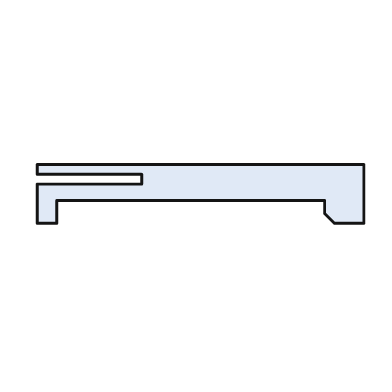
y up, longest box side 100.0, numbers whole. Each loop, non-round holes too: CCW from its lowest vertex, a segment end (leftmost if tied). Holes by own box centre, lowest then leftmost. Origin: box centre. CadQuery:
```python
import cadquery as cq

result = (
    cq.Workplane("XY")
    .moveTo(-50.0, -9.0)
    .lineTo(-44.0, -9.0)
    .lineTo(-44.0, -2.0)
    .lineTo(38.0, -2.0)
    .lineTo(38.0, -6.0)
    .lineTo(41.0, -9.0)
    .lineTo(50.0, -9.0)
    .lineTo(50.0, 9.0)
    .lineTo(-50.0, 9.0)
    .lineTo(-50.0, 6.0)
    .lineTo(-18.0, 6.0)
    .lineTo(-18.0, 3.0)
    .lineTo(-50.0, 3.0)
    .close()
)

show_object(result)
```